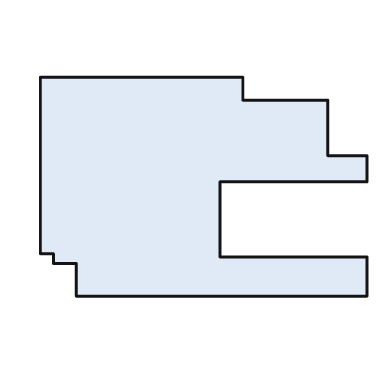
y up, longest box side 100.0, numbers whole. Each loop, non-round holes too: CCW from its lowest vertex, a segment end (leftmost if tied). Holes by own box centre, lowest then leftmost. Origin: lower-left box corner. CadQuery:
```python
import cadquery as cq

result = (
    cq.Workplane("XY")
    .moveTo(11.0, 0.0)
    .lineTo(100.0, 0.0)
    .lineTo(100.0, 12.0)
    .lineTo(55.0, 12.0)
    .lineTo(55.0, 35.0)
    .lineTo(100.0, 35.0)
    .lineTo(100.0, 43.0)
    .lineTo(88.0, 43.0)
    .lineTo(88.0, 60.0)
    .lineTo(62.0, 60.0)
    .lineTo(62.0, 67.0)
    .lineTo(0.0, 67.0)
    .lineTo(0.0, 13.0)
    .lineTo(4.0, 13.0)
    .lineTo(4.0, 10.0)
    .lineTo(11.0, 10.0)
    .close()
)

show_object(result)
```